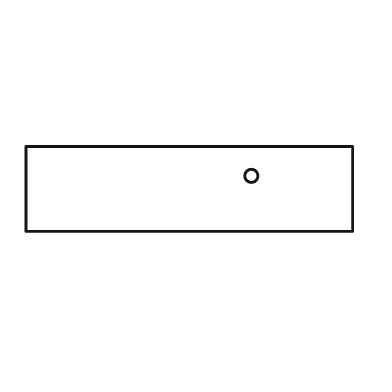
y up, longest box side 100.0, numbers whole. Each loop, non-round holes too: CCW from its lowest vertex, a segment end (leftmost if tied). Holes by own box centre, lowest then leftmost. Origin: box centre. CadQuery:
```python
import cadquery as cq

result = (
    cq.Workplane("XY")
    .moveTo(-50.0, -13.0)
    .lineTo(50.0, -13.0)
    .lineTo(50.0, 13.0)
    .lineTo(-50.0, 13.0)
    .close()
    .moveTo(19.0, 4.0)
    .circle(2.0)
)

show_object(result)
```